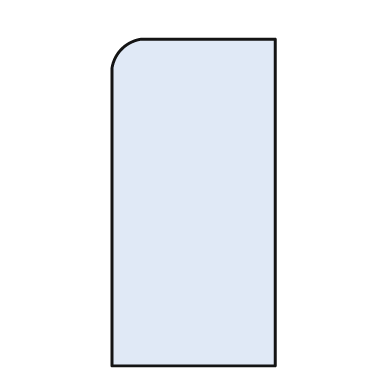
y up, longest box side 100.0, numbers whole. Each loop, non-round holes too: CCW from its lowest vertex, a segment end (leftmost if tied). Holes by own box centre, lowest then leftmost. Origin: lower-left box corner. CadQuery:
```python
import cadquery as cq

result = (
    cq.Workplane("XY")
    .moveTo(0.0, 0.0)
    .lineTo(50.0, 0.0)
    .lineTo(50.0, 100.0)
    .lineTo(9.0, 100.0)
    .threePointArc((3.0, 97.0), (0.0, 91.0))
    .close()
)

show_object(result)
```